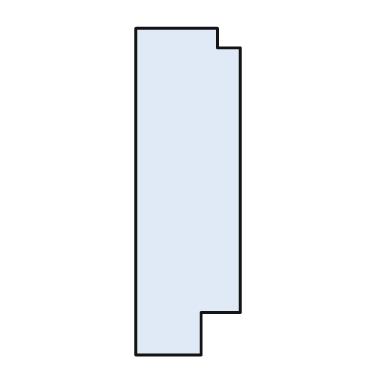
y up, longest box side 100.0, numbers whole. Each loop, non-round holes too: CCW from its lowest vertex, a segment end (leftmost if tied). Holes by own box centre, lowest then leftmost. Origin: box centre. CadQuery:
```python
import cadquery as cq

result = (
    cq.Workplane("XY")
    .moveTo(-16.0, -50.0)
    .lineTo(4.0, -50.0)
    .lineTo(4.0, -37.0)
    .lineTo(16.0, -37.0)
    .lineTo(16.0, 44.0)
    .lineTo(9.0, 44.0)
    .lineTo(9.0, 50.0)
    .lineTo(-16.0, 50.0)
    .close()
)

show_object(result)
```